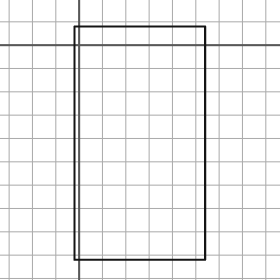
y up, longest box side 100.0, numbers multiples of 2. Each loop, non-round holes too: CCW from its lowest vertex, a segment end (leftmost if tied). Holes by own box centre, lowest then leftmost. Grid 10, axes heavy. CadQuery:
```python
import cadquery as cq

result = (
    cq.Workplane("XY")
    .moveTo(-2.0, -92.0)
    .lineTo(54.0, -92.0)
    .lineTo(54.0, 8.0)
    .lineTo(-2.0, 8.0)
    .close()
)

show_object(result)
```